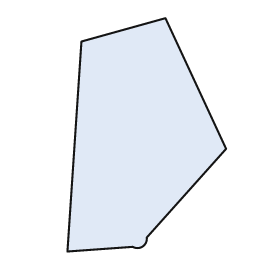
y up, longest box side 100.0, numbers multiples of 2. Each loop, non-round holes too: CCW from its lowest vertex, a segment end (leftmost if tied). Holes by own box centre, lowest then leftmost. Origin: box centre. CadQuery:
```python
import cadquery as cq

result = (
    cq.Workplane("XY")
    .moveTo(-34.0, -50.0)
    .lineTo(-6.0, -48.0)
    .threePointArc((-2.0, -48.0), (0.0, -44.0))
    .lineTo(34.0, -6.0)
    .lineTo(8.0, 50.0)
    .lineTo(-28.0, 40.0)
    .close()
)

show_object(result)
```